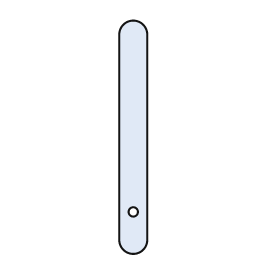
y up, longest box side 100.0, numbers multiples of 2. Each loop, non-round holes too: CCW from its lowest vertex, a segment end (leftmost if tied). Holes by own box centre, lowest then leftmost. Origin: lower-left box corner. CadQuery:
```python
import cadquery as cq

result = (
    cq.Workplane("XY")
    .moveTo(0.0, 6.0)
    .threePointArc((6.0, 0.0), (12.0, 6.0))
    .lineTo(12.0, 94.0)
    .threePointArc((6.0, 100.0), (0.0, 94.0))
    .close()
    .moveTo(6.0, 18.0)
    .circle(2.0)
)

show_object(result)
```